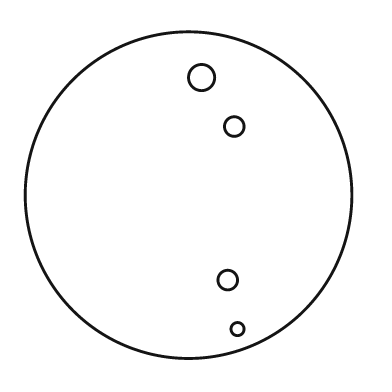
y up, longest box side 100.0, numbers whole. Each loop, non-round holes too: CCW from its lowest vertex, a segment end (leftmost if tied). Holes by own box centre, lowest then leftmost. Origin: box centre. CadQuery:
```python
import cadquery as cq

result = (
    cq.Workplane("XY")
    .moveTo(0.0, 0.0)
    .circle(50.0)
    .moveTo(15.0, -41.0)
    .circle(2.0)
    .moveTo(12.0, -26.0)
    .circle(3.0)
    .moveTo(14.0, 21.0)
    .circle(3.0)
    .moveTo(4.0, 36.0)
    .circle(4.0)
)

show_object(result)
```